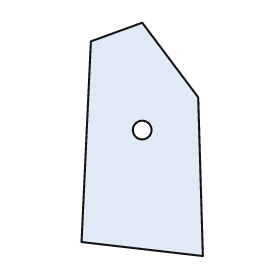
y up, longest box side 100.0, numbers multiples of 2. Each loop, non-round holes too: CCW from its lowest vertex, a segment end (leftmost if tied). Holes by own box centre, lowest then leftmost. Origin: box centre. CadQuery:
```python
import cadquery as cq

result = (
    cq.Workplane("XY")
    .moveTo(26.0, -50.0)
    .lineTo(24.0, 18.0)
    .lineTo(0.0, 50.0)
    .lineTo(-22.0, 42.0)
    .lineTo(-26.0, -44.0)
    .close()
    .moveTo(0.0, 4.0)
    .circle(4.0)
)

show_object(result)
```